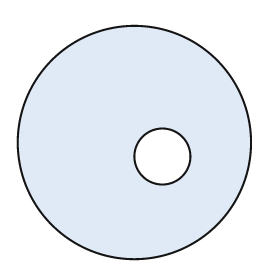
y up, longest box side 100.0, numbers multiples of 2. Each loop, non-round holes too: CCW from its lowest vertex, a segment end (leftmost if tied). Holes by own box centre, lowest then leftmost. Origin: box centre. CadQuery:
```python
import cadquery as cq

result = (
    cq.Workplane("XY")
    .moveTo(0.0, 0.0)
    .circle(50.0)
    .moveTo(12.0, -6.0)
    .circle(12.0)
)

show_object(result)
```